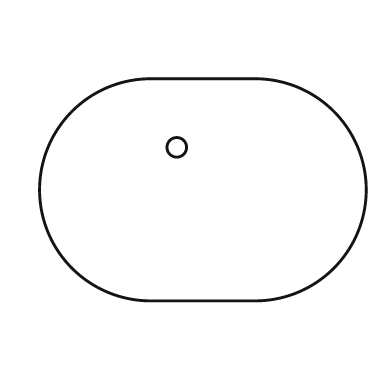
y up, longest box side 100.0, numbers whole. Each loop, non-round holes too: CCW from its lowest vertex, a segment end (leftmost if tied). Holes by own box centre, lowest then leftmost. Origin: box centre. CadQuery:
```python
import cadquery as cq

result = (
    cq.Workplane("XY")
    .moveTo(-16.0, -34.0)
    .lineTo(16.0, -34.0)
    .threePointArc((50.0, 0.0), (16.0, 34.0))
    .lineTo(-16.0, 34.0)
    .threePointArc((-50.0, 0.0), (-16.0, -34.0))
    .close()
    .moveTo(-8.0, 13.0)
    .circle(3.0)
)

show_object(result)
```